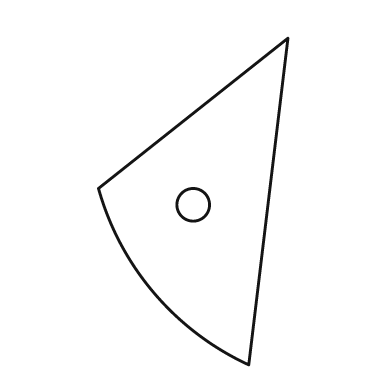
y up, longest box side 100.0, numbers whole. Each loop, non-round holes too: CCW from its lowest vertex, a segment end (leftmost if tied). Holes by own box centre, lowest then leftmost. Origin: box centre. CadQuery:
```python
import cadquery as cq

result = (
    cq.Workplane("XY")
    .moveTo(17.0, -50.0)
    .lineTo(29.0, 50.0)
    .lineTo(-29.0, 4.0)
    .threePointArc((-12.0, -28.0), (17.0, -50.0))
    .close()
    .moveTo(0.0, -1.0)
    .circle(5.0)
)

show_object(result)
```